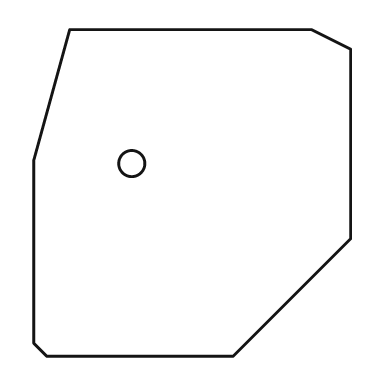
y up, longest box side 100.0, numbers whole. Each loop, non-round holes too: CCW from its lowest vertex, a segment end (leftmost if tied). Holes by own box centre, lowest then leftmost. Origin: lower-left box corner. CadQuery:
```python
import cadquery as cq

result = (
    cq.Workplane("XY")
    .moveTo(4.0, 0.0)
    .lineTo(61.0, 0.0)
    .lineTo(97.0, 36.0)
    .lineTo(97.0, 94.0)
    .lineTo(85.0, 100.0)
    .lineTo(11.0, 100.0)
    .lineTo(0.0, 60.0)
    .lineTo(0.0, 4.0)
    .close()
    .moveTo(30.0, 59.0)
    .circle(4.0)
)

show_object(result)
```